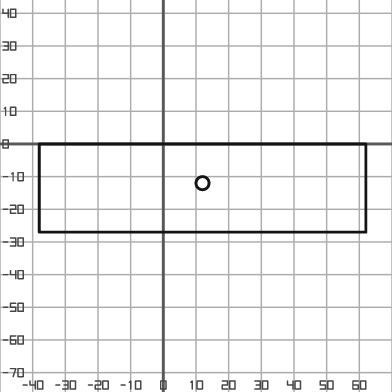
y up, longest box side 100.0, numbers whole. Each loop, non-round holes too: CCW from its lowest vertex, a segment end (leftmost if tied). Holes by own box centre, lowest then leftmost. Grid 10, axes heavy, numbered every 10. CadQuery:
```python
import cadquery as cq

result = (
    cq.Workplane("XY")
    .moveTo(-38.0, -27.0)
    .lineTo(62.0, -27.0)
    .lineTo(62.0, 0.0)
    .lineTo(-38.0, 0.0)
    .close()
    .moveTo(12.0, -12.0)
    .circle(2.0)
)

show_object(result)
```